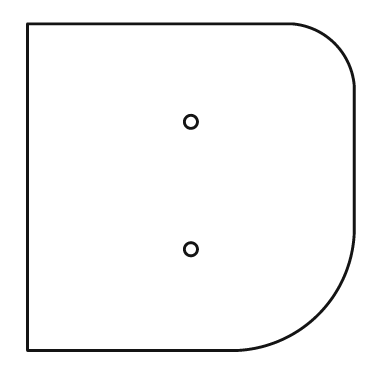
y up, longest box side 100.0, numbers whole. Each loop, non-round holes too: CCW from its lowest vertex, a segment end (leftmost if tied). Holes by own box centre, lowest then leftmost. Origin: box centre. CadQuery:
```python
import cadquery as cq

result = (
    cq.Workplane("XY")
    .moveTo(-50.0, -50.0)
    .lineTo(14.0, -50.0)
    .threePointArc((39.0, -39.0), (50.0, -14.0))
    .lineTo(50.0, 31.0)
    .threePointArc((44.0, 44.0), (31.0, 50.0))
    .lineTo(-50.0, 50.0)
    .close()
    .moveTo(0.0, -19.0)
    .circle(2.0)
    .moveTo(0.0, 20.0)
    .circle(2.0)
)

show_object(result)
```